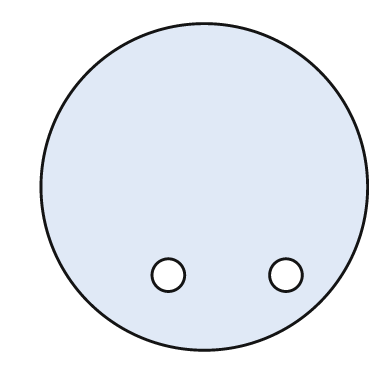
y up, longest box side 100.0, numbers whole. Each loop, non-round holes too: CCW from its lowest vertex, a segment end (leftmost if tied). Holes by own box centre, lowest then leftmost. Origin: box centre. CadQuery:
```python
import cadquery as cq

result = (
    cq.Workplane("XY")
    .moveTo(0.0, 0.0)
    .circle(50.0)
    .moveTo(-11.0, -27.0)
    .circle(5.0)
    .moveTo(25.0, -27.0)
    .circle(5.0)
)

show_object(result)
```